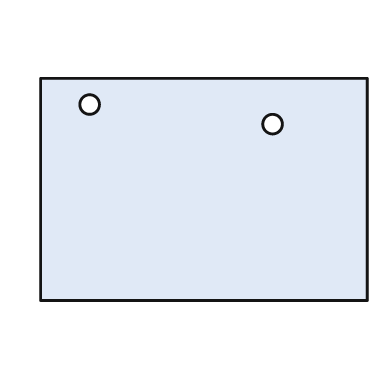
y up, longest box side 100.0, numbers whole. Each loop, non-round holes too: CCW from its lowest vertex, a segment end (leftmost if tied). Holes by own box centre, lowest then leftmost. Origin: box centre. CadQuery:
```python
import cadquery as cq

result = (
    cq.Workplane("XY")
    .moveTo(-50.0, -34.0)
    .lineTo(50.0, -34.0)
    .lineTo(50.0, 34.0)
    .lineTo(-50.0, 34.0)
    .close()
    .moveTo(21.0, 20.0)
    .circle(3.0)
    .moveTo(-35.0, 26.0)
    .circle(3.0)
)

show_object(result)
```